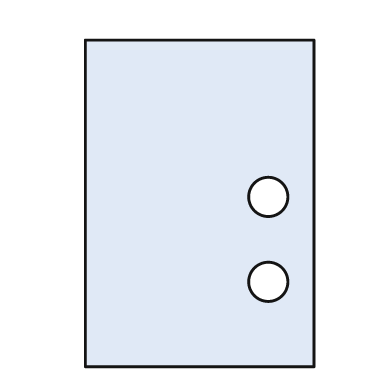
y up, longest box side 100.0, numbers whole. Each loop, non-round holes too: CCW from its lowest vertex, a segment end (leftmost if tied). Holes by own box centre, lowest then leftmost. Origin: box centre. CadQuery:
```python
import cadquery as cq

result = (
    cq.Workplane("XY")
    .moveTo(-35.0, -50.0)
    .lineTo(35.0, -50.0)
    .lineTo(35.0, 50.0)
    .lineTo(-35.0, 50.0)
    .close()
    .moveTo(21.0, -24.0)
    .circle(6.0)
    .moveTo(21.0, 2.0)
    .circle(6.0)
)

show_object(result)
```